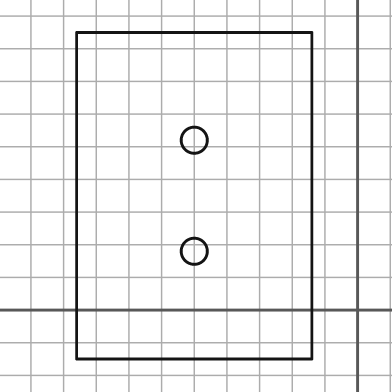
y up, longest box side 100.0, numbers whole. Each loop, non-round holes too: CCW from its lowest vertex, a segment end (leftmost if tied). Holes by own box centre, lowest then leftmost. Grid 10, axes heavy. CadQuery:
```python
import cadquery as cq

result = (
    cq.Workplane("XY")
    .moveTo(-86.0, -15.0)
    .lineTo(-14.0, -15.0)
    .lineTo(-14.0, 85.0)
    .lineTo(-86.0, 85.0)
    .close()
    .moveTo(-50.0, 18.0)
    .circle(4.0)
    .moveTo(-50.0, 52.0)
    .circle(4.0)
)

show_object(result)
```